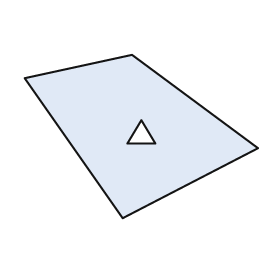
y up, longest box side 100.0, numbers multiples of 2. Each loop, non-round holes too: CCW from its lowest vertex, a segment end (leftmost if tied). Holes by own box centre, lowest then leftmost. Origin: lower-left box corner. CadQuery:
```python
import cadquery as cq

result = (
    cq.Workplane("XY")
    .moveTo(42.0, 0.0)
    .lineTo(100.0, 30.0)
    .lineTo(46.0, 70.0)
    .lineTo(0.0, 60.0)
    .close()
    .moveTo(44.0, 32.0)
    .lineTo(56.0, 32.0)
    .lineTo(50.0, 42.0)
    .close()
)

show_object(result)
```